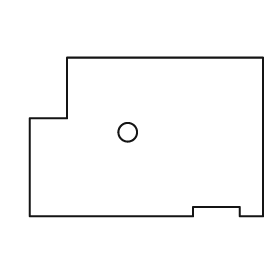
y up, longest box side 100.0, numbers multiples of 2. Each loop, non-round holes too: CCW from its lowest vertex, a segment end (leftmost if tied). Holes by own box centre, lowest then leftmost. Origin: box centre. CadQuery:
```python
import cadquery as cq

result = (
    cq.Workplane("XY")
    .moveTo(-50.0, -34.0)
    .lineTo(20.0, -34.0)
    .lineTo(20.0, -30.0)
    .lineTo(40.0, -30.0)
    .lineTo(40.0, -34.0)
    .lineTo(50.0, -34.0)
    .lineTo(50.0, 34.0)
    .lineTo(-34.0, 34.0)
    .lineTo(-34.0, 8.0)
    .lineTo(-50.0, 8.0)
    .close()
    .moveTo(-8.0, 2.0)
    .circle(4.0)
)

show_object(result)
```